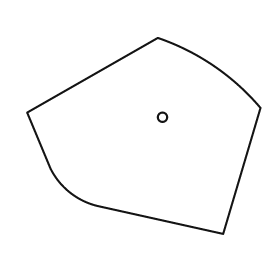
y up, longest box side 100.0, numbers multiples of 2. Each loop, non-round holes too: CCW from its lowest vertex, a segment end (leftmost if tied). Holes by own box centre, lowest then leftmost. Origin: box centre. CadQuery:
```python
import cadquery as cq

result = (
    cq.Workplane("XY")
    .moveTo(34.0, -42.0)
    .lineTo(50.0, 12.0)
    .threePointArc((30.0, 30.0), (6.0, 42.0))
    .lineTo(-50.0, 10.0)
    .lineTo(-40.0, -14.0)
    .threePointArc((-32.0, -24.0), (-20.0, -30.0))
    .close()
    .moveTo(8.0, 8.0)
    .circle(2.0)
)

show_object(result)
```